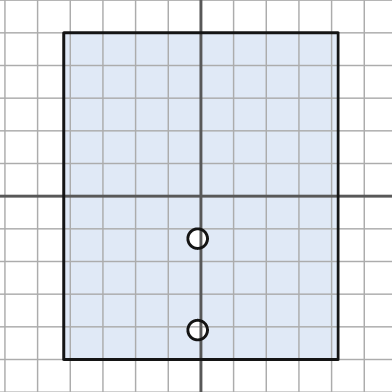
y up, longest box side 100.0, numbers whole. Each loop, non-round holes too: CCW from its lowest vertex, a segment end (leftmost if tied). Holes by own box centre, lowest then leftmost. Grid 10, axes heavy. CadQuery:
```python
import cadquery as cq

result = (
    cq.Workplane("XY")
    .moveTo(-42.0, -50.0)
    .lineTo(42.0, -50.0)
    .lineTo(42.0, 50.0)
    .lineTo(-42.0, 50.0)
    .close()
    .moveTo(-1.0, -41.0)
    .circle(3.0)
    .moveTo(-1.0, -13.0)
    .circle(3.0)
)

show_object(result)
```